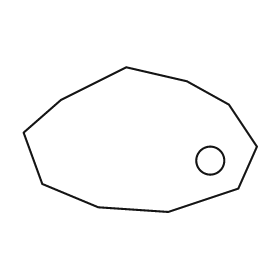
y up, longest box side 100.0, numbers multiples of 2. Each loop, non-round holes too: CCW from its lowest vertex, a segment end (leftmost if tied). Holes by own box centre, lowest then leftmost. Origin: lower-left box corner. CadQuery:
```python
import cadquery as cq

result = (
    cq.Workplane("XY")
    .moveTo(62.0, 0.0)
    .lineTo(92.0, 10.0)
    .lineTo(100.0, 28.0)
    .lineTo(88.0, 46.0)
    .lineTo(70.0, 56.0)
    .lineTo(44.0, 62.0)
    .lineTo(16.0, 48.0)
    .lineTo(0.0, 34.0)
    .lineTo(8.0, 12.0)
    .lineTo(32.0, 2.0)
    .close()
    .moveTo(80.0, 22.0)
    .circle(6.0)
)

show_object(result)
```